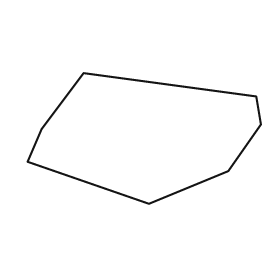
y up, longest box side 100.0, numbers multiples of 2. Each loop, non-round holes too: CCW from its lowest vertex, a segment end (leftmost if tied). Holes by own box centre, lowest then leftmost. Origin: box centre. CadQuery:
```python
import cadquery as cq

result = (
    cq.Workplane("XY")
    .moveTo(2.0, -28.0)
    .lineTo(36.0, -14.0)
    .lineTo(50.0, 6.0)
    .lineTo(48.0, 18.0)
    .lineTo(-26.0, 28.0)
    .lineTo(-44.0, 4.0)
    .lineTo(-50.0, -10.0)
    .close()
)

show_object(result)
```